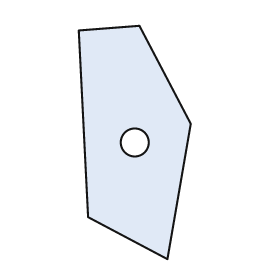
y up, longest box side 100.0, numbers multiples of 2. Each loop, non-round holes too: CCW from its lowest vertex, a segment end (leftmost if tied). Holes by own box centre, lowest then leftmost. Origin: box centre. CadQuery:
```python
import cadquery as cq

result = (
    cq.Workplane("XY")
    .moveTo(14.0, -50.0)
    .lineTo(24.0, 8.0)
    .lineTo(2.0, 50.0)
    .lineTo(-24.0, 48.0)
    .lineTo(-20.0, -32.0)
    .close()
    .moveTo(0.0, 0.0)
    .circle(6.0)
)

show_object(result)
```